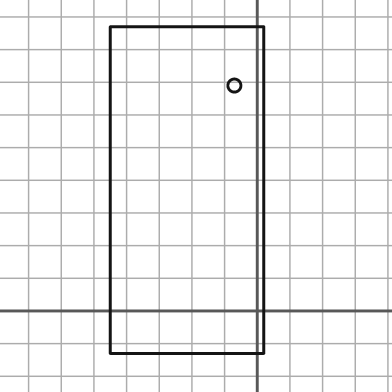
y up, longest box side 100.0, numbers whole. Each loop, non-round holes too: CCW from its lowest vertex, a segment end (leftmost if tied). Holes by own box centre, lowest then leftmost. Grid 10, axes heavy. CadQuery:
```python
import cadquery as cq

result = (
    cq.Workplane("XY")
    .moveTo(-45.0, -13.0)
    .lineTo(2.0, -13.0)
    .lineTo(2.0, 87.0)
    .lineTo(-45.0, 87.0)
    .close()
    .moveTo(-7.0, 69.0)
    .circle(2.0)
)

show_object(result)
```